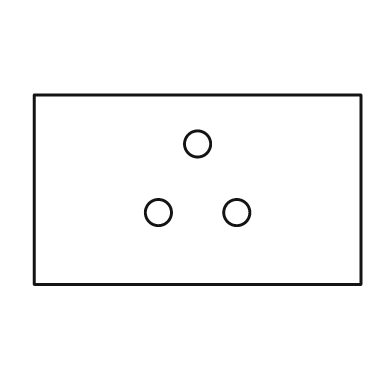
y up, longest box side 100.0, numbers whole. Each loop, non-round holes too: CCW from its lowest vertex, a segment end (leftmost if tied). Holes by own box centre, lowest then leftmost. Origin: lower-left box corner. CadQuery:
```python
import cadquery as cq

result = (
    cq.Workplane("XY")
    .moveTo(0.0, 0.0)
    .lineTo(100.0, 0.0)
    .lineTo(100.0, 58.0)
    .lineTo(0.0, 58.0)
    .close()
    .moveTo(38.0, 22.0)
    .circle(4.0)
    .moveTo(62.0, 22.0)
    .circle(4.0)
    .moveTo(50.0, 43.0)
    .circle(4.0)
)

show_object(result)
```